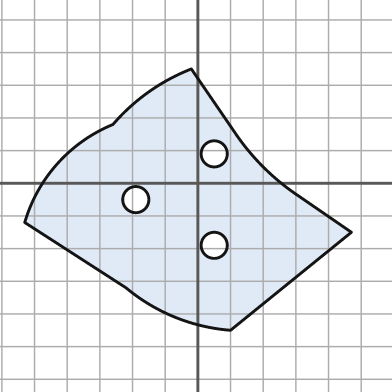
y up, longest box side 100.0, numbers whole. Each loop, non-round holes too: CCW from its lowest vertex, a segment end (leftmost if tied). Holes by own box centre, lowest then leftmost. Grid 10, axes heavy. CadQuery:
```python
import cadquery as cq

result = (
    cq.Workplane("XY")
    .moveTo(10.0, -45.0)
    .lineTo(47.0, -15.0)
    .lineTo(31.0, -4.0)
    .threePointArc((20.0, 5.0), (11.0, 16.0))
    .lineTo(-2.0, 35.0)
    .threePointArc((-15.0, 28.0), (-26.0, 18.0))
    .threePointArc((-43.0, 6.0), (-53.0, -12.0))
    .lineTo(-22.0, -32.0)
    .threePointArc((-7.0, -41.0), (10.0, -45.0))
    .close()
    .moveTo(5.0, -19.0)
    .circle(4.0)
    .moveTo(-19.0, -5.0)
    .circle(4.0)
    .moveTo(5.0, 9.0)
    .circle(4.0)
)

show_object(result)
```